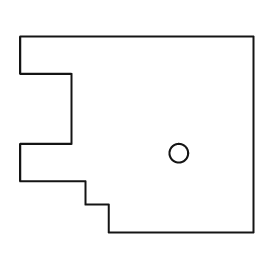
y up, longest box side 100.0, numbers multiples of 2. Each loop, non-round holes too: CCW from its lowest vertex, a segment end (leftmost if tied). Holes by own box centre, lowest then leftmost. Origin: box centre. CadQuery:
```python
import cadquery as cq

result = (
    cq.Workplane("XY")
    .moveTo(-12.0, -42.0)
    .lineTo(50.0, -42.0)
    .lineTo(50.0, 42.0)
    .lineTo(-50.0, 42.0)
    .lineTo(-50.0, 26.0)
    .lineTo(-28.0, 26.0)
    .lineTo(-28.0, -4.0)
    .lineTo(-50.0, -4.0)
    .lineTo(-50.0, -20.0)
    .lineTo(-22.0, -20.0)
    .lineTo(-22.0, -30.0)
    .lineTo(-12.0, -30.0)
    .close()
    .moveTo(18.0, -8.0)
    .circle(4.0)
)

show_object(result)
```